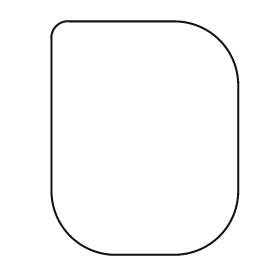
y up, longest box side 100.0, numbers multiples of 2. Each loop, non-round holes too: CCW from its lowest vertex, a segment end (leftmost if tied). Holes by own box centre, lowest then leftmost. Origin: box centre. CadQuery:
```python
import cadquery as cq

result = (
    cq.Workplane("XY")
    .moveTo(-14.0, -50.0)
    .lineTo(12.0, -50.0)
    .threePointArc((32.0, -42.0), (40.0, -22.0))
    .lineTo(40.0, 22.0)
    .threePointArc((32.0, 42.0), (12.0, 50.0))
    .lineTo(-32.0, 50.0)
    .threePointArc((-38.0, 48.0), (-40.0, 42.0))
    .lineTo(-40.0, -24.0)
    .threePointArc((-32.0, -42.0), (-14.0, -50.0))
    .close()
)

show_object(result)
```